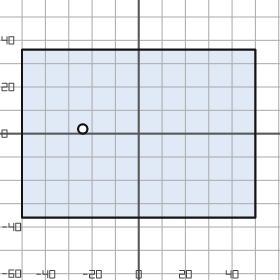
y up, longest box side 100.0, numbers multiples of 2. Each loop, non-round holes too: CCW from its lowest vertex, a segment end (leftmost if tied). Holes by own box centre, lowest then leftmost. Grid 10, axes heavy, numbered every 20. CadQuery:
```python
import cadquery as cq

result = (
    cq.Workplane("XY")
    .moveTo(-50.0, -36.0)
    .lineTo(50.0, -36.0)
    .lineTo(50.0, 36.0)
    .lineTo(-50.0, 36.0)
    .close()
    .moveTo(-24.0, 2.0)
    .circle(2.0)
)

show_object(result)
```